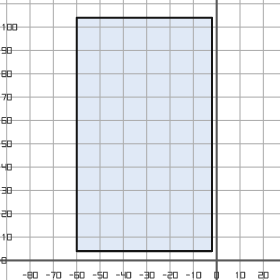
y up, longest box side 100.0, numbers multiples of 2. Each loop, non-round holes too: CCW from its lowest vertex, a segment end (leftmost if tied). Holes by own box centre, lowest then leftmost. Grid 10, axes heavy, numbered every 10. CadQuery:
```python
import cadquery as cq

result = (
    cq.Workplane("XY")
    .moveTo(-60.0, 4.0)
    .lineTo(-2.0, 4.0)
    .lineTo(-2.0, 104.0)
    .lineTo(-60.0, 104.0)
    .close()
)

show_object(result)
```